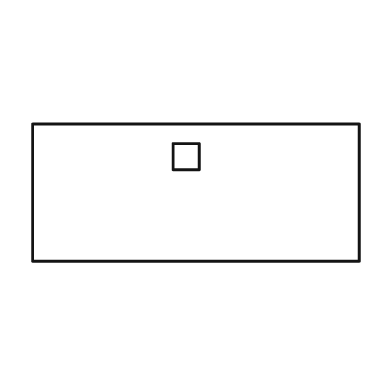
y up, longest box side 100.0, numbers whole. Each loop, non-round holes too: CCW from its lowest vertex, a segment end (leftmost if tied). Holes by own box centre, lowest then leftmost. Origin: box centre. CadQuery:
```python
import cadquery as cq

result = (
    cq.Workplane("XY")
    .moveTo(-50.0, -21.0)
    .lineTo(50.0, -21.0)
    .lineTo(50.0, 21.0)
    .lineTo(-50.0, 21.0)
    .close()
    .moveTo(-7.0, 7.0)
    .lineTo(1.0, 7.0)
    .lineTo(1.0, 15.0)
    .lineTo(-7.0, 15.0)
    .close()
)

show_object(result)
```